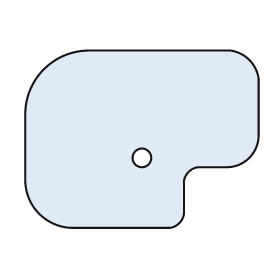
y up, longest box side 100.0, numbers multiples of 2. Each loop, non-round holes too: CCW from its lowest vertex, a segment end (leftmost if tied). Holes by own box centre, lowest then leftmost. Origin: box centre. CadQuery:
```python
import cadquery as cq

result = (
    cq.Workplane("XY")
    .moveTo(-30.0, -38.0)
    .lineTo(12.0, -38.0)
    .threePointArc((16.0, -36.0), (18.0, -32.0))
    .lineTo(18.0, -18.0)
    .threePointArc((20.0, -14.0), (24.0, -12.0))
    .lineTo(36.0, -12.0)
    .threePointArc((46.0, -8.0), (50.0, 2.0))
    .lineTo(50.0, 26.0)
    .threePointArc((46.0, 34.0), (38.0, 38.0))
    .lineTo(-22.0, 38.0)
    .threePointArc((-42.0, 30.0), (-50.0, 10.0))
    .lineTo(-50.0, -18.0)
    .threePointArc((-44.0, -32.0), (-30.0, -38.0))
    .close()
    .moveTo(0.0, -8.0)
    .circle(4.0)
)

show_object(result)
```